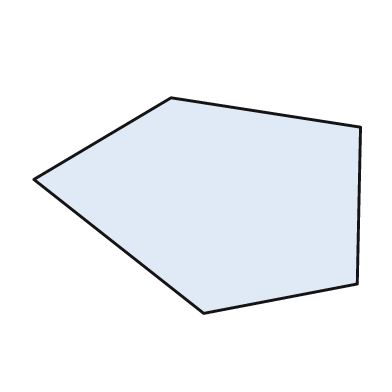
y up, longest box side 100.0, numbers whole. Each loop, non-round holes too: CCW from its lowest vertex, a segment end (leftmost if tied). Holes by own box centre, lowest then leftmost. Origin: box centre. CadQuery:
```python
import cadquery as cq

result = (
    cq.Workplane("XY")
    .moveTo(2.0, -33.0)
    .lineTo(49.0, -24.0)
    .lineTo(50.0, 24.0)
    .lineTo(-8.0, 33.0)
    .lineTo(-50.0, 8.0)
    .close()
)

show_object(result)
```